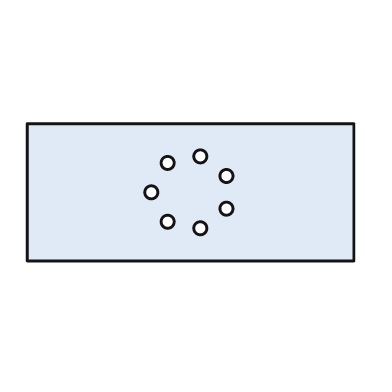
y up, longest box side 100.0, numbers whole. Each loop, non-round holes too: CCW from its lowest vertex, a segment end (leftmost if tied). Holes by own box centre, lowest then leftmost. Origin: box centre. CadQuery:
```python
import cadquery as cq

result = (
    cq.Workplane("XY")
    .moveTo(-50.0, -21.0)
    .lineTo(50.0, -21.0)
    .lineTo(50.0, 21.0)
    .lineTo(-50.0, 21.0)
    .close()
    .moveTo(3.0, -11.0)
    .circle(2.0)
    .moveTo(-7.0, -9.0)
    .circle(2.0)
    .moveTo(11.0, -5.0)
    .circle(2.0)
    .moveTo(-12.0, 0.0)
    .circle(2.0)
    .moveTo(11.0, 5.0)
    .circle(2.0)
    .moveTo(-7.0, 9.0)
    .circle(2.0)
    .moveTo(3.0, 11.0)
    .circle(2.0)
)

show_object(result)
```